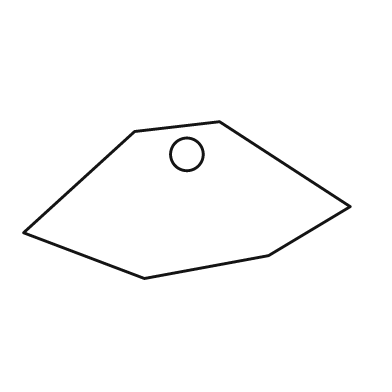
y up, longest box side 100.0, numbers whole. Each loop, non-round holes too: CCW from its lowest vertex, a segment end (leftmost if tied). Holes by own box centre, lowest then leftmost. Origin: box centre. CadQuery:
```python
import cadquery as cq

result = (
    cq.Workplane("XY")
    .moveTo(-13.0, -24.0)
    .lineTo(25.0, -17.0)
    .lineTo(50.0, -2.0)
    .lineTo(10.0, 24.0)
    .lineTo(-16.0, 21.0)
    .lineTo(-50.0, -10.0)
    .close()
    .moveTo(0.0, 14.0)
    .circle(5.0)
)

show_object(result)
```